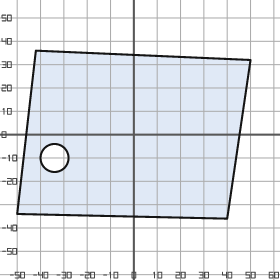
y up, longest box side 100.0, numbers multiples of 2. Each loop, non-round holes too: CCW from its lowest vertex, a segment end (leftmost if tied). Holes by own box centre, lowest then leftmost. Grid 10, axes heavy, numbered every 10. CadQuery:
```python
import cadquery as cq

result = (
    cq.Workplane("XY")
    .moveTo(40.0, -36.0)
    .lineTo(50.0, 32.0)
    .lineTo(-42.0, 36.0)
    .lineTo(-50.0, -34.0)
    .close()
    .moveTo(-34.0, -10.0)
    .circle(6.0)
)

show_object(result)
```